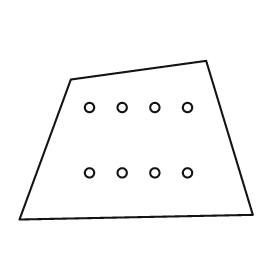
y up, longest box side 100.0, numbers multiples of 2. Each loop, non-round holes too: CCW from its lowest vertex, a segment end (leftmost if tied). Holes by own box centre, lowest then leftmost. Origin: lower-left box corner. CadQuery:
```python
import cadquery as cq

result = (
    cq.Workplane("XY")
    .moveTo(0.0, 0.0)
    .lineTo(100.0, 2.0)
    .lineTo(80.0, 68.0)
    .lineTo(22.0, 60.0)
    .close()
    .moveTo(30.0, 20.0)
    .circle(2.0)
    .moveTo(44.0, 20.0)
    .circle(2.0)
    .moveTo(58.0, 20.0)
    .circle(2.0)
    .moveTo(72.0, 20.0)
    .circle(2.0)
    .moveTo(30.0, 48.0)
    .circle(2.0)
    .moveTo(44.0, 48.0)
    .circle(2.0)
    .moveTo(58.0, 48.0)
    .circle(2.0)
    .moveTo(72.0, 48.0)
    .circle(2.0)
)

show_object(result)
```